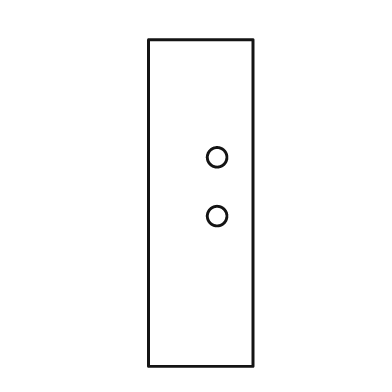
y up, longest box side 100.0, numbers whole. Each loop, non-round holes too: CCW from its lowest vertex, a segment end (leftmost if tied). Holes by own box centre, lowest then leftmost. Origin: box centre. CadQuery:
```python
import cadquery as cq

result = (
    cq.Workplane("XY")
    .moveTo(-16.0, -50.0)
    .lineTo(16.0, -50.0)
    .lineTo(16.0, 50.0)
    .lineTo(-16.0, 50.0)
    .close()
    .moveTo(5.0, -4.0)
    .circle(3.0)
    .moveTo(5.0, 14.0)
    .circle(3.0)
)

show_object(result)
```